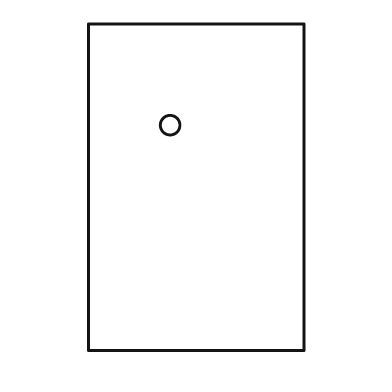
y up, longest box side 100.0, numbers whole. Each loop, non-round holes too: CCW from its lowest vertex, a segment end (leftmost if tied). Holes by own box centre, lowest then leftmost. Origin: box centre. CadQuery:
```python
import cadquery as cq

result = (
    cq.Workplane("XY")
    .moveTo(-33.0, -50.0)
    .lineTo(33.0, -50.0)
    .lineTo(33.0, 50.0)
    .lineTo(-33.0, 50.0)
    .close()
    .moveTo(-8.0, 19.0)
    .circle(3.0)
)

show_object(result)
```